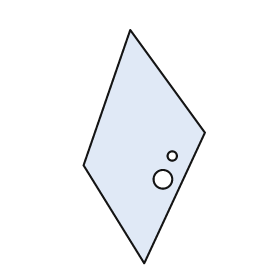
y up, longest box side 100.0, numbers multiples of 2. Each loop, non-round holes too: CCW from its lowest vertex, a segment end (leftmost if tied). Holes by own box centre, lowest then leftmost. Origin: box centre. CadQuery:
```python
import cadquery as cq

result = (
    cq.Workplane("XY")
    .moveTo(0.0, -50.0)
    .lineTo(26.0, 6.0)
    .lineTo(-6.0, 50.0)
    .lineTo(-26.0, -8.0)
    .close()
    .moveTo(8.0, -14.0)
    .circle(4.0)
    .moveTo(12.0, -4.0)
    .circle(2.0)
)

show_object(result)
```